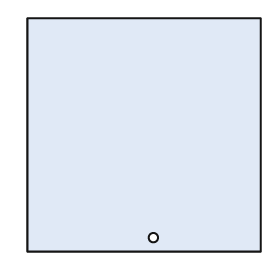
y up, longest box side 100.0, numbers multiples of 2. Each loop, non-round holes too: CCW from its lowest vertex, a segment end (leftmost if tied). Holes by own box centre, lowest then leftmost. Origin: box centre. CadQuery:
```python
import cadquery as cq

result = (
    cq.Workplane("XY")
    .moveTo(-50.0, -50.0)
    .lineTo(50.0, -50.0)
    .lineTo(50.0, 50.0)
    .lineTo(-50.0, 50.0)
    .close()
    .moveTo(4.0, -44.0)
    .circle(2.0)
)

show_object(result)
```